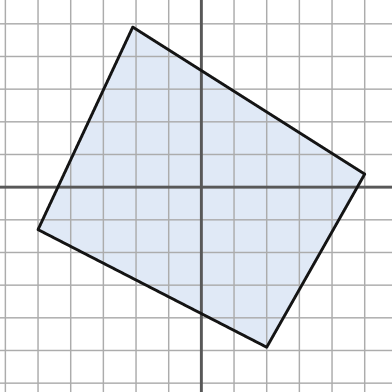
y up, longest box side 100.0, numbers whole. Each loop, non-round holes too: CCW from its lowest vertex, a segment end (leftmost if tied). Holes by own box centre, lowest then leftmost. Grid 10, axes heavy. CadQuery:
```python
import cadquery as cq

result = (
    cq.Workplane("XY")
    .moveTo(20.0, -49.0)
    .lineTo(50.0, 4.0)
    .lineTo(-21.0, 49.0)
    .lineTo(-50.0, -13.0)
    .close()
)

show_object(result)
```